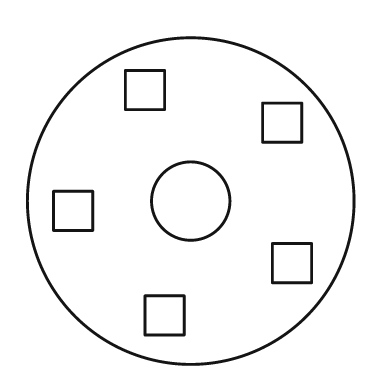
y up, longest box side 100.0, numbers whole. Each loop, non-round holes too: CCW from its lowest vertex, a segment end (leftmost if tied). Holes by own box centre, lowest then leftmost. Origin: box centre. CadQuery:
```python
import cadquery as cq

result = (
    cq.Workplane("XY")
    .moveTo(0.0, 0.0)
    .circle(50.0)
    .moveTo(-14.0, -41.0)
    .lineTo(-2.0, -41.0)
    .lineTo(-2.0, -29.0)
    .lineTo(-14.0, -29.0)
    .close()
    .moveTo(25.0, -25.0)
    .lineTo(37.0, -25.0)
    .lineTo(37.0, -13.0)
    .lineTo(25.0, -13.0)
    .close()
    .moveTo(-42.0, -9.0)
    .lineTo(-30.0, -9.0)
    .lineTo(-30.0, 3.0)
    .lineTo(-42.0, 3.0)
    .close()
    .moveTo(0.0, 0.0)
    .circle(12.0)
    .moveTo(22.0, 18.0)
    .lineTo(34.0, 18.0)
    .lineTo(34.0, 30.0)
    .lineTo(22.0, 30.0)
    .close()
    .moveTo(-20.0, 28.0)
    .lineTo(-8.0, 28.0)
    .lineTo(-8.0, 40.0)
    .lineTo(-20.0, 40.0)
    .close()
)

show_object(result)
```